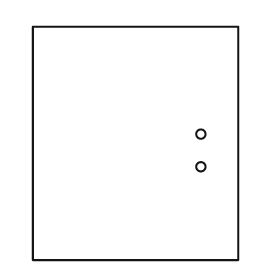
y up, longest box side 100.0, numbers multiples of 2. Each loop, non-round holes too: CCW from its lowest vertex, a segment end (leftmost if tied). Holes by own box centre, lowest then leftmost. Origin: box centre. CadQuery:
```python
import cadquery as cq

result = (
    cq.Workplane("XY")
    .moveTo(-44.0, -50.0)
    .lineTo(44.0, -50.0)
    .lineTo(44.0, 50.0)
    .lineTo(-44.0, 50.0)
    .close()
    .moveTo(28.0, -10.0)
    .circle(2.0)
    .moveTo(28.0, 4.0)
    .circle(2.0)
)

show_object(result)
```